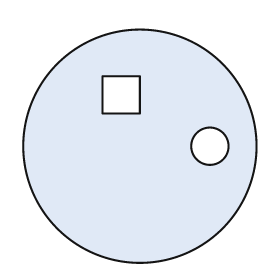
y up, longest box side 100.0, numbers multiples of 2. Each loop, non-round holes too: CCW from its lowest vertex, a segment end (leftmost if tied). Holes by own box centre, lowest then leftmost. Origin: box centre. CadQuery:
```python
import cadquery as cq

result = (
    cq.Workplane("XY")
    .moveTo(0.0, 0.0)
    .circle(50.0)
    .moveTo(30.0, 0.0)
    .circle(8.0)
    .moveTo(-16.0, 14.0)
    .lineTo(0.0, 14.0)
    .lineTo(0.0, 30.0)
    .lineTo(-16.0, 30.0)
    .close()
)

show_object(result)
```